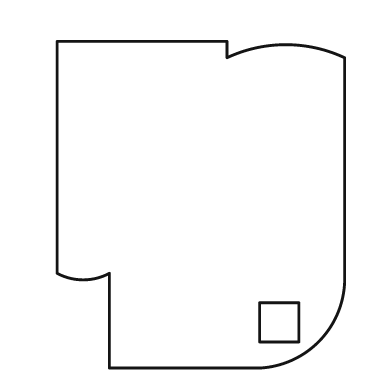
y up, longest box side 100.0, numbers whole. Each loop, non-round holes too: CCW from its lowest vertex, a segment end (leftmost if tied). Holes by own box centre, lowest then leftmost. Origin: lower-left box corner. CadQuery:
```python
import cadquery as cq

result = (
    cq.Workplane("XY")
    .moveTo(16.0, 0.0)
    .lineTo(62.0, 0.0)
    .threePointArc((80.0, 8.0), (88.0, 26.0))
    .lineTo(88.0, 95.0)
    .threePointArc((70.0, 99.0), (52.0, 95.0))
    .lineTo(52.0, 100.0)
    .lineTo(0.0, 100.0)
    .lineTo(0.0, 29.0)
    .threePointArc((8.0, 27.0), (16.0, 29.0))
    .close()
    .moveTo(62.0, 8.0)
    .lineTo(74.0, 8.0)
    .lineTo(74.0, 20.0)
    .lineTo(62.0, 20.0)
    .close()
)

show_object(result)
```